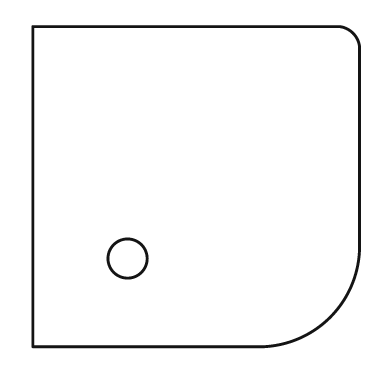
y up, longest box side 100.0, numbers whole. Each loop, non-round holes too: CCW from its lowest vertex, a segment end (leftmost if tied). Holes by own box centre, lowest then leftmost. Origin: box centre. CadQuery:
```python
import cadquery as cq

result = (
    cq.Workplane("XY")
    .moveTo(-50.0, -49.0)
    .lineTo(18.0, -49.0)
    .threePointArc((41.0, -40.0), (50.0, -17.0))
    .lineTo(50.0, 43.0)
    .threePointArc((48.0, 47.0), (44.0, 49.0))
    .lineTo(-50.0, 49.0)
    .close()
    .moveTo(-21.0, -22.0)
    .circle(6.0)
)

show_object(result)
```